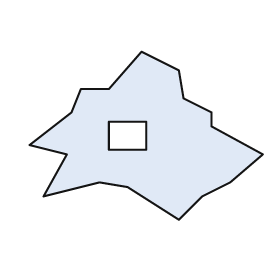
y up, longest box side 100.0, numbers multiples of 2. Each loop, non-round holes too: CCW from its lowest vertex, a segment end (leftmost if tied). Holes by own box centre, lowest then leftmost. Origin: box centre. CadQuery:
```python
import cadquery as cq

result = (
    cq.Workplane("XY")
    .moveTo(14.0, -36.0)
    .lineTo(24.0, -26.0)
    .lineTo(36.0, -20.0)
    .lineTo(50.0, -8.0)
    .lineTo(28.0, 4.0)
    .lineTo(28.0, 10.0)
    .lineTo(16.0, 16.0)
    .lineTo(14.0, 28.0)
    .lineTo(-2.0, 36.0)
    .lineTo(-16.0, 20.0)
    .lineTo(-28.0, 20.0)
    .lineTo(-32.0, 10.0)
    .lineTo(-50.0, -4.0)
    .lineTo(-34.0, -8.0)
    .lineTo(-44.0, -26.0)
    .lineTo(-20.0, -20.0)
    .lineTo(-8.0, -22.0)
    .close()
    .moveTo(-16.0, -6.0)
    .lineTo(0.0, -6.0)
    .lineTo(0.0, 6.0)
    .lineTo(-16.0, 6.0)
    .close()
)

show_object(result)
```